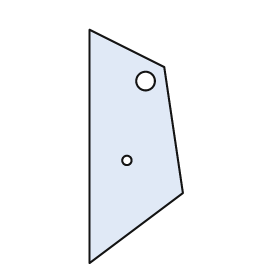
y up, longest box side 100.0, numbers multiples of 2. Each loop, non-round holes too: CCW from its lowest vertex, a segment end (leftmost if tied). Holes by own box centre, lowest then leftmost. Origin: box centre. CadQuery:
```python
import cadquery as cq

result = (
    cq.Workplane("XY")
    .moveTo(-20.0, -50.0)
    .lineTo(20.0, -20.0)
    .lineTo(12.0, 34.0)
    .lineTo(-20.0, 50.0)
    .close()
    .moveTo(-4.0, -6.0)
    .circle(2.0)
    .moveTo(4.0, 28.0)
    .circle(4.0)
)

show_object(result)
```